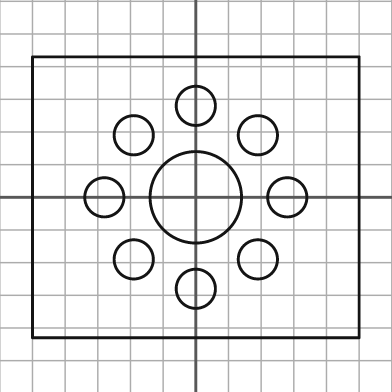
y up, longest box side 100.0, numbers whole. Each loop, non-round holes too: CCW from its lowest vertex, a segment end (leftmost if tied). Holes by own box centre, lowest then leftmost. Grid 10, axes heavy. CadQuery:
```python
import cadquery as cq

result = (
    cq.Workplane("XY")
    .moveTo(-50.0, -43.0)
    .lineTo(50.0, -43.0)
    .lineTo(50.0, 43.0)
    .lineTo(-50.0, 43.0)
    .close()
    .moveTo(0.0, -28.0)
    .circle(6.0)
    .moveTo(-19.0, -19.0)
    .circle(6.0)
    .moveTo(19.0, -19.0)
    .circle(6.0)
    .moveTo(-28.0, 0.0)
    .circle(6.0)
    .moveTo(0.0, 0.0)
    .circle(14.0)
    .moveTo(28.0, 0.0)
    .circle(6.0)
    .moveTo(-19.0, 19.0)
    .circle(6.0)
    .moveTo(19.0, 19.0)
    .circle(6.0)
    .moveTo(0.0, 28.0)
    .circle(6.0)
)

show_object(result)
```